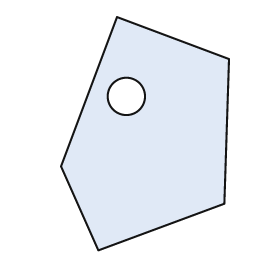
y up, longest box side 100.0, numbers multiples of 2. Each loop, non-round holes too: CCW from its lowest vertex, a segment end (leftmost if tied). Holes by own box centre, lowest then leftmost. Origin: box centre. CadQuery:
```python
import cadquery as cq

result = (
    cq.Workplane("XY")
    .moveTo(-20.0, -50.0)
    .lineTo(34.0, -30.0)
    .lineTo(36.0, 32.0)
    .lineTo(-12.0, 50.0)
    .lineTo(-36.0, -14.0)
    .close()
    .moveTo(-8.0, 16.0)
    .circle(8.0)
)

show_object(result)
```